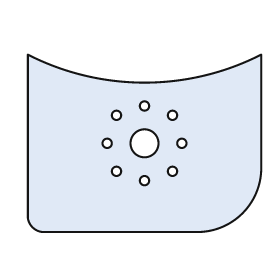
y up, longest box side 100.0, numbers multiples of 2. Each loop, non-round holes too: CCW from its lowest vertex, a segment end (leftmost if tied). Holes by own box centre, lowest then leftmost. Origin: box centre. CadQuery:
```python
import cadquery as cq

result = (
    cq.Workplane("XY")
    .moveTo(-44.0, -38.0)
    .lineTo(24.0, -38.0)
    .threePointArc((42.0, -30.0), (50.0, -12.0))
    .lineTo(50.0, 38.0)
    .threePointArc((0.0, 26.0), (-50.0, 38.0))
    .lineTo(-50.0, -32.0)
    .threePointArc((-48.0, -36.0), (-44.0, -38.0))
    .close()
    .moveTo(0.0, -16.0)
    .circle(2.0)
    .moveTo(-12.0, -12.0)
    .circle(2.0)
    .moveTo(12.0, -12.0)
    .circle(2.0)
    .moveTo(-16.0, 0.0)
    .circle(2.0)
    .moveTo(0.0, 0.0)
    .circle(6.0)
    .moveTo(16.0, 0.0)
    .circle(2.0)
    .moveTo(-12.0, 12.0)
    .circle(2.0)
    .moveTo(12.0, 12.0)
    .circle(2.0)
    .moveTo(0.0, 16.0)
    .circle(2.0)
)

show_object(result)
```